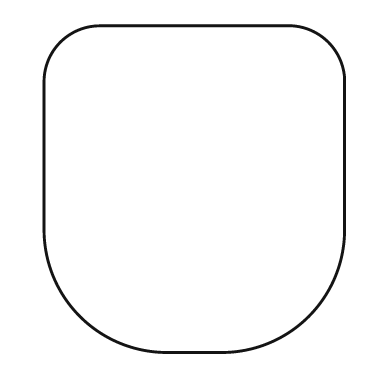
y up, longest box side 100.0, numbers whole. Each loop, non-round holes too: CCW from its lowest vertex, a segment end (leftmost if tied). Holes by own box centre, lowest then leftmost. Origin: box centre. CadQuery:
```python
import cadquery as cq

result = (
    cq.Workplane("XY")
    .moveTo(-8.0, -50.0)
    .lineTo(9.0, -50.0)
    .threePointArc((35.0, -39.0), (46.0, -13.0))
    .lineTo(46.0, 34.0)
    .threePointArc((41.0, 45.0), (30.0, 50.0))
    .lineTo(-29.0, 50.0)
    .threePointArc((-41.0, 45.0), (-46.0, 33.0))
    .lineTo(-46.0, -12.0)
    .threePointArc((-35.0, -39.0), (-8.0, -50.0))
    .close()
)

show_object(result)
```